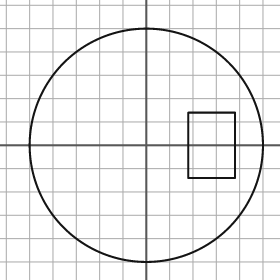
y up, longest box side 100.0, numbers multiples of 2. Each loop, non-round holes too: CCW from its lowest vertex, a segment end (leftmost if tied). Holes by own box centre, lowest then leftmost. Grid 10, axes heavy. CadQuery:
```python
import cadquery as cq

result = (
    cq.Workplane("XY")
    .moveTo(0.0, 0.0)
    .circle(50.0)
    .moveTo(18.0, -14.0)
    .lineTo(38.0, -14.0)
    .lineTo(38.0, 14.0)
    .lineTo(18.0, 14.0)
    .close()
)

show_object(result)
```